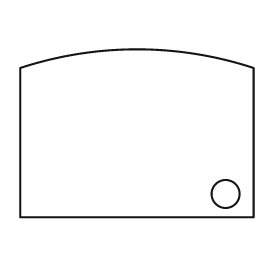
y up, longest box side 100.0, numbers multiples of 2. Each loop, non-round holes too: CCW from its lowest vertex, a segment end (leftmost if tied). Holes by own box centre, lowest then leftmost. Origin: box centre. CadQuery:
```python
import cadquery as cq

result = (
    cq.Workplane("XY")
    .moveTo(-50.0, -36.0)
    .lineTo(50.0, -36.0)
    .lineTo(50.0, 28.0)
    .threePointArc((0.0, 36.0), (-50.0, 28.0))
    .close()
    .moveTo(38.0, -26.0)
    .circle(6.0)
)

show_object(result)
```